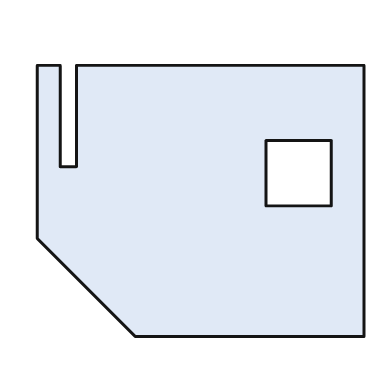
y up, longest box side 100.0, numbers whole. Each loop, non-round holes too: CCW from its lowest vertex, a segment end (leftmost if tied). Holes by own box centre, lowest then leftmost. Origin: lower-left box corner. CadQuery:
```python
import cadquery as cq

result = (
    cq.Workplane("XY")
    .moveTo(30.0, 0.0)
    .lineTo(100.0, 0.0)
    .lineTo(100.0, 83.0)
    .lineTo(12.0, 83.0)
    .lineTo(12.0, 52.0)
    .lineTo(7.0, 52.0)
    .lineTo(7.0, 83.0)
    .lineTo(0.0, 83.0)
    .lineTo(0.0, 30.0)
    .close()
    .moveTo(70.0, 40.0)
    .lineTo(90.0, 40.0)
    .lineTo(90.0, 60.0)
    .lineTo(70.0, 60.0)
    .close()
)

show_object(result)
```